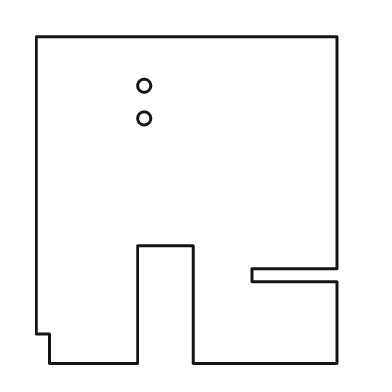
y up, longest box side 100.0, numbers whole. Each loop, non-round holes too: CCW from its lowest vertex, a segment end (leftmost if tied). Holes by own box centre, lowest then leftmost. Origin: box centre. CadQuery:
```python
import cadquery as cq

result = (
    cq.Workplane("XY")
    .moveTo(-42.0, -50.0)
    .lineTo(-15.0, -50.0)
    .lineTo(-15.0, -14.0)
    .lineTo(2.0, -14.0)
    .lineTo(2.0, -50.0)
    .lineTo(46.0, -50.0)
    .lineTo(46.0, -25.0)
    .lineTo(20.0, -25.0)
    .lineTo(20.0, -21.0)
    .lineTo(46.0, -21.0)
    .lineTo(46.0, 50.0)
    .lineTo(-46.0, 50.0)
    .lineTo(-46.0, -41.0)
    .lineTo(-42.0, -41.0)
    .close()
    .moveTo(-13.0, 25.0)
    .circle(2.0)
    .moveTo(-13.0, 35.0)
    .circle(2.0)
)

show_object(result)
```